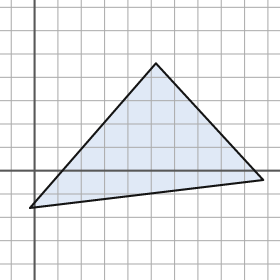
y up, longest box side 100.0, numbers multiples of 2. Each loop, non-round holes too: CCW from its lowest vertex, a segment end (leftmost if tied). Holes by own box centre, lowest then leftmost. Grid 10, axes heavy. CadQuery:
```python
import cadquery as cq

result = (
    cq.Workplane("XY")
    .moveTo(-2.0, -16.0)
    .lineTo(98.0, -4.0)
    .lineTo(52.0, 46.0)
    .close()
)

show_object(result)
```